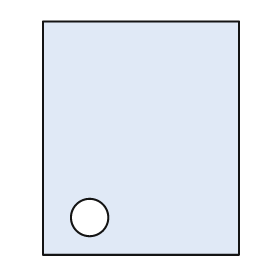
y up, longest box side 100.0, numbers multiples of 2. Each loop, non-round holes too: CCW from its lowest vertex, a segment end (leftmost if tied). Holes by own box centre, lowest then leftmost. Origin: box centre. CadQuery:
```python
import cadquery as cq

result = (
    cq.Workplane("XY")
    .moveTo(-42.0, -50.0)
    .lineTo(42.0, -50.0)
    .lineTo(42.0, 50.0)
    .lineTo(-42.0, 50.0)
    .close()
    .moveTo(-22.0, -34.0)
    .circle(8.0)
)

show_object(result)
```